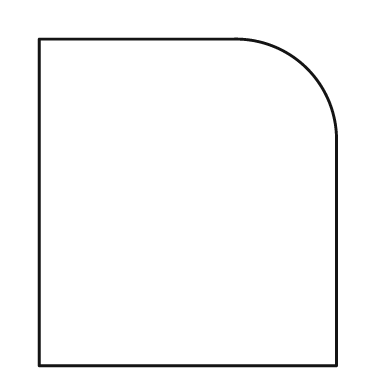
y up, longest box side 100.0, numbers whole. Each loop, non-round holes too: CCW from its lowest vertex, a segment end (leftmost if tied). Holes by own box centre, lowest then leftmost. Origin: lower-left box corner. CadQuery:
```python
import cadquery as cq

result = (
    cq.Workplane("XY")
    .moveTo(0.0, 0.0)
    .lineTo(91.0, 0.0)
    .lineTo(91.0, 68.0)
    .threePointArc((82.0, 91.0), (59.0, 100.0))
    .lineTo(0.0, 100.0)
    .close()
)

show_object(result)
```